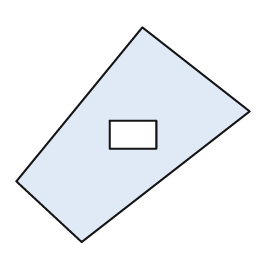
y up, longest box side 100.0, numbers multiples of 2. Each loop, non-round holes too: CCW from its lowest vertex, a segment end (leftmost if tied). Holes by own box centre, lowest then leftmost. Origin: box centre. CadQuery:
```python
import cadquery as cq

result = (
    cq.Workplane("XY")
    .moveTo(-22.0, -46.0)
    .lineTo(50.0, 10.0)
    .lineTo(4.0, 46.0)
    .lineTo(-50.0, -20.0)
    .close()
    .moveTo(-10.0, -6.0)
    .lineTo(10.0, -6.0)
    .lineTo(10.0, 6.0)
    .lineTo(-10.0, 6.0)
    .close()
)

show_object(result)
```